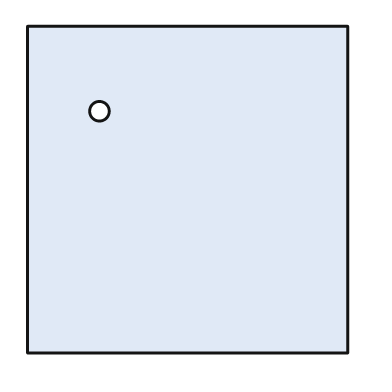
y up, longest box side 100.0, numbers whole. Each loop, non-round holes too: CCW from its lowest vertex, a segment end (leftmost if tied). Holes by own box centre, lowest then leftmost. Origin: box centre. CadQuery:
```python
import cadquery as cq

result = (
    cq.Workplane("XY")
    .moveTo(-49.0, -50.0)
    .lineTo(49.0, -50.0)
    .lineTo(49.0, 50.0)
    .lineTo(-49.0, 50.0)
    .close()
    .moveTo(-27.0, 24.0)
    .circle(3.0)
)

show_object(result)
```